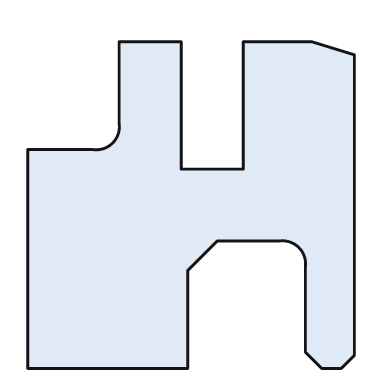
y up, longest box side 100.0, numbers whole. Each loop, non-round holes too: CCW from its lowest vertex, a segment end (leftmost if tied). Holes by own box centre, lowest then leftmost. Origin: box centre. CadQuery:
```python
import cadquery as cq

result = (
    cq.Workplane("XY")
    .moveTo(-50.0, -50.0)
    .lineTo(-1.0, -50.0)
    .lineTo(-1.0, -20.0)
    .lineTo(8.0, -11.0)
    .lineTo(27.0, -11.0)
    .threePointArc((33.0, -13.0), (35.0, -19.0))
    .lineTo(35.0, -45.0)
    .lineTo(40.0, -50.0)
    .lineTo(46.0, -50.0)
    .lineTo(50.0, -46.0)
    .lineTo(50.0, 46.0)
    .lineTo(37.0, 50.0)
    .lineTo(16.0, 50.0)
    .lineTo(16.0, 11.0)
    .lineTo(-3.0, 11.0)
    .lineTo(-3.0, 50.0)
    .lineTo(-22.0, 50.0)
    .lineTo(-22.0, 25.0)
    .threePointArc((-24.0, 19.0), (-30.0, 17.0))
    .lineTo(-50.0, 17.0)
    .close()
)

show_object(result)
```